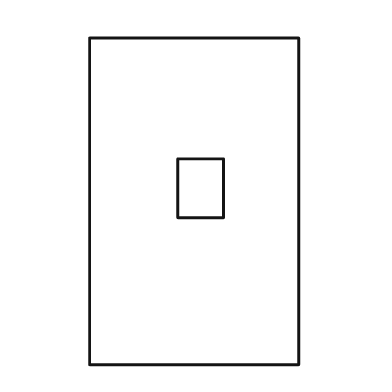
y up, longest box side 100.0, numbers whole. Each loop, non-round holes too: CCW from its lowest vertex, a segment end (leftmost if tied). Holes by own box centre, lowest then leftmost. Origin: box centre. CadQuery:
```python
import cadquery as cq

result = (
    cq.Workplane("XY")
    .moveTo(-32.0, -50.0)
    .lineTo(32.0, -50.0)
    .lineTo(32.0, 50.0)
    .lineTo(-32.0, 50.0)
    .close()
    .moveTo(-5.0, -5.0)
    .lineTo(9.0, -5.0)
    .lineTo(9.0, 13.0)
    .lineTo(-5.0, 13.0)
    .close()
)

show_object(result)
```